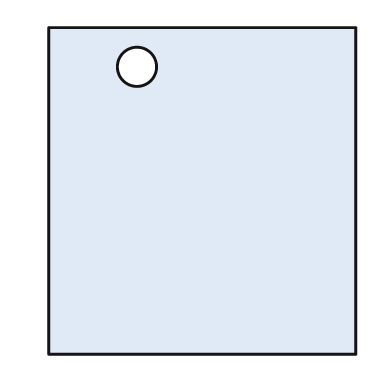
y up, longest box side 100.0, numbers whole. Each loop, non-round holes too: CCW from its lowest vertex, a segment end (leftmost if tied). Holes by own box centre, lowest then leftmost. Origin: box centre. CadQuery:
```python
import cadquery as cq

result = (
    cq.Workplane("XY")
    .moveTo(-47.0, -50.0)
    .lineTo(47.0, -50.0)
    .lineTo(47.0, 50.0)
    .lineTo(-47.0, 50.0)
    .close()
    .moveTo(-20.0, 38.0)
    .circle(6.0)
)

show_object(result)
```